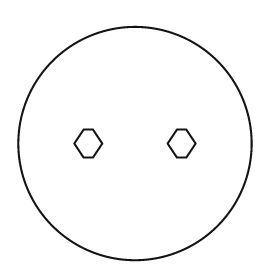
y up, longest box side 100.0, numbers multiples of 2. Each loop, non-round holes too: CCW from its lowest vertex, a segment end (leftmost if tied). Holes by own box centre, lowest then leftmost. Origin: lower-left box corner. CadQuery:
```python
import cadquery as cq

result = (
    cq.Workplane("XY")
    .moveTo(50.0, 50.0)
    .circle(50.0)
    .moveTo(28.0, 44.0)
    .lineTo(32.0, 44.0)
    .lineTo(36.0, 50.0)
    .lineTo(32.0, 56.0)
    .lineTo(28.0, 56.0)
    .lineTo(24.0, 50.0)
    .close()
    .moveTo(68.0, 44.0)
    .lineTo(72.0, 44.0)
    .lineTo(76.0, 50.0)
    .lineTo(72.0, 56.0)
    .lineTo(68.0, 56.0)
    .lineTo(64.0, 50.0)
    .close()
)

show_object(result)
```